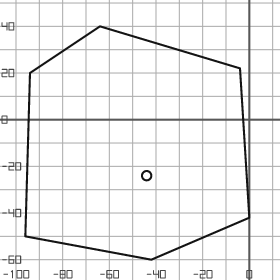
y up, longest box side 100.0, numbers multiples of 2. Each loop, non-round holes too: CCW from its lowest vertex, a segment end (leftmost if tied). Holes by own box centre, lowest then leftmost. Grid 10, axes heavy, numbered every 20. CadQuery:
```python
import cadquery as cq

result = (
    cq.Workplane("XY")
    .moveTo(-42.0, -60.0)
    .lineTo(0.0, -42.0)
    .lineTo(-4.0, 22.0)
    .lineTo(-64.0, 40.0)
    .lineTo(-94.0, 20.0)
    .lineTo(-96.0, -50.0)
    .close()
    .moveTo(-44.0, -24.0)
    .circle(2.0)
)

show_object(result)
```